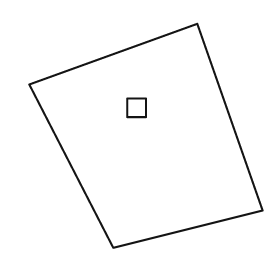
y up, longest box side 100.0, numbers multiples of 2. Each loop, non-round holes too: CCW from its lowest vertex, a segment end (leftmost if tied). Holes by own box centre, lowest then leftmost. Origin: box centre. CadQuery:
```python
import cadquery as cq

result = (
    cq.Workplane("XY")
    .moveTo(-14.0, -48.0)
    .lineTo(50.0, -32.0)
    .lineTo(22.0, 48.0)
    .lineTo(-50.0, 22.0)
    .close()
    .moveTo(-8.0, 8.0)
    .lineTo(0.0, 8.0)
    .lineTo(0.0, 16.0)
    .lineTo(-8.0, 16.0)
    .close()
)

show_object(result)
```